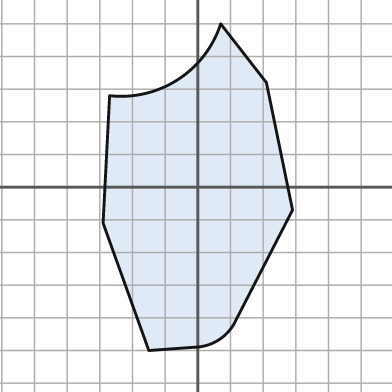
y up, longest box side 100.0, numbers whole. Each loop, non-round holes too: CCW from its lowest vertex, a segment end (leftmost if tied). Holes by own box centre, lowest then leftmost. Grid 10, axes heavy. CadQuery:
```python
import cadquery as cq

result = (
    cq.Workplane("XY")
    .moveTo(-15.0, -50.0)
    .lineTo(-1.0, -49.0)
    .threePointArc((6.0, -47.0), (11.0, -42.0))
    .lineTo(29.0, -7.0)
    .lineTo(21.0, 32.0)
    .lineTo(7.0, 50.0)
    .threePointArc((-6.0, 33.0), (-27.0, 28.0))
    .lineTo(-29.0, -11.0)
    .close()
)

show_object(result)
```